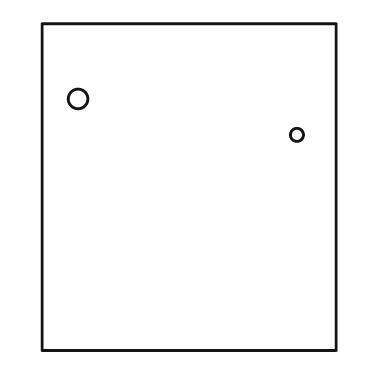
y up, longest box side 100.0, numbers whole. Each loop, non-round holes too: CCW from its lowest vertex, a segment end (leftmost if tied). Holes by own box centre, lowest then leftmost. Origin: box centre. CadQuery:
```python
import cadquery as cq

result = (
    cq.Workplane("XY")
    .moveTo(-45.0, -50.0)
    .lineTo(45.0, -50.0)
    .lineTo(45.0, 50.0)
    .lineTo(-45.0, 50.0)
    .close()
    .moveTo(33.0, 16.0)
    .circle(2.0)
    .moveTo(-34.0, 27.0)
    .circle(3.0)
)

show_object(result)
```